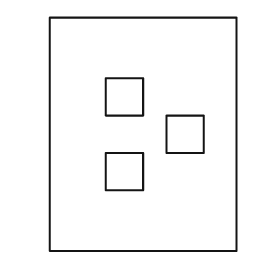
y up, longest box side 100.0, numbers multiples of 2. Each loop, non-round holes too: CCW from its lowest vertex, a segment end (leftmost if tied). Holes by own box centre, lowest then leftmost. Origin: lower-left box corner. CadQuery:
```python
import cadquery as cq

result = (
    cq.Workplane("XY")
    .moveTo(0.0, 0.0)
    .lineTo(80.0, 0.0)
    .lineTo(80.0, 100.0)
    .lineTo(0.0, 100.0)
    .close()
    .moveTo(24.0, 26.0)
    .lineTo(40.0, 26.0)
    .lineTo(40.0, 42.0)
    .lineTo(24.0, 42.0)
    .close()
    .moveTo(50.0, 42.0)
    .lineTo(66.0, 42.0)
    .lineTo(66.0, 58.0)
    .lineTo(50.0, 58.0)
    .close()
    .moveTo(24.0, 58.0)
    .lineTo(40.0, 58.0)
    .lineTo(40.0, 74.0)
    .lineTo(24.0, 74.0)
    .close()
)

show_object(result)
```